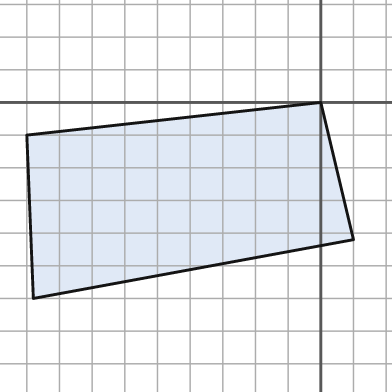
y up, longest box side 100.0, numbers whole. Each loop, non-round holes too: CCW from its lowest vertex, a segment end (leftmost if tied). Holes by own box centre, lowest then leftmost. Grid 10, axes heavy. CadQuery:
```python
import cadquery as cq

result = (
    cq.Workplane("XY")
    .moveTo(-88.0, -60.0)
    .lineTo(10.0, -42.0)
    .lineTo(0.0, 0.0)
    .lineTo(-90.0, -10.0)
    .close()
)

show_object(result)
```